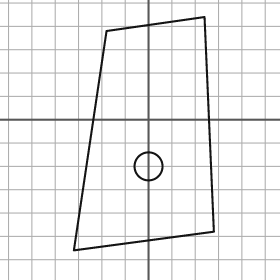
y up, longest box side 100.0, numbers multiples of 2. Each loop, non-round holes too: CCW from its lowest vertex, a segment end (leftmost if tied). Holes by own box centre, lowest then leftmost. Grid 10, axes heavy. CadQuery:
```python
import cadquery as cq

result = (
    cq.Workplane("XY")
    .moveTo(-32.0, -56.0)
    .lineTo(28.0, -48.0)
    .lineTo(24.0, 44.0)
    .lineTo(-18.0, 38.0)
    .close()
    .moveTo(0.0, -20.0)
    .circle(6.0)
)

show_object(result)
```